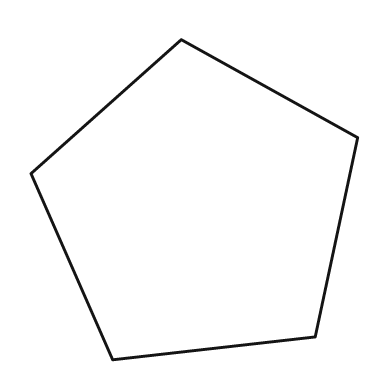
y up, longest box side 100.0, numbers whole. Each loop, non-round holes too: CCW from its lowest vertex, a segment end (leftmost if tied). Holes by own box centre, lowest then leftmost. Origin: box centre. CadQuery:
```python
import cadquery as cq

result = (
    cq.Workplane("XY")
    .moveTo(-25.0, -49.0)
    .lineTo(37.0, -42.0)
    .lineTo(50.0, 19.0)
    .lineTo(-4.0, 49.0)
    .lineTo(-50.0, 8.0)
    .close()
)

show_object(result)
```